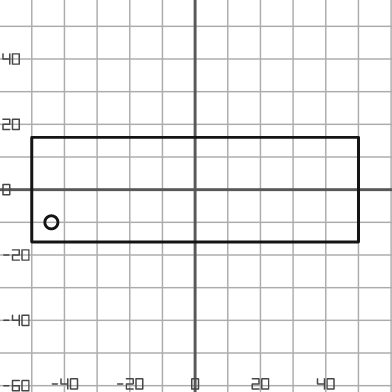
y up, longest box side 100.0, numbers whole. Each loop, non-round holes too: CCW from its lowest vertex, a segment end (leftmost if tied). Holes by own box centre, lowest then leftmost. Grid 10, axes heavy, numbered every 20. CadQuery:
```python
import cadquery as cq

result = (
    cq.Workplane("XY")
    .moveTo(-50.0, -16.0)
    .lineTo(50.0, -16.0)
    .lineTo(50.0, 16.0)
    .lineTo(-50.0, 16.0)
    .close()
    .moveTo(-44.0, -10.0)
    .circle(2.0)
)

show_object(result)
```